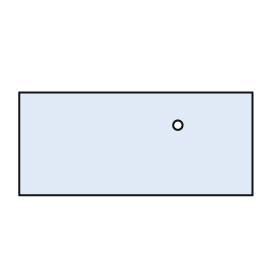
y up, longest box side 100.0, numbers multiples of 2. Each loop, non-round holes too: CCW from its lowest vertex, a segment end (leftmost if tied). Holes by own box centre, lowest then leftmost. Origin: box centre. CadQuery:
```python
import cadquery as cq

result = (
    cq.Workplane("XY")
    .moveTo(-50.0, -22.0)
    .lineTo(50.0, -22.0)
    .lineTo(50.0, 22.0)
    .lineTo(-50.0, 22.0)
    .close()
    .moveTo(18.0, 8.0)
    .circle(2.0)
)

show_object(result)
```